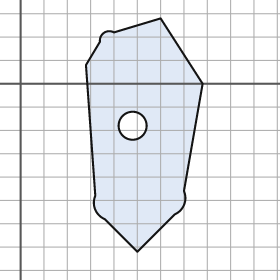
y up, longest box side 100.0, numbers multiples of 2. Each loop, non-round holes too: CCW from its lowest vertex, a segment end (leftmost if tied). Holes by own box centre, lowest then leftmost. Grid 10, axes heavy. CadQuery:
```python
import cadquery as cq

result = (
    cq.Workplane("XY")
    .moveTo(50.0, -72.0)
    .lineTo(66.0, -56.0)
    .threePointArc((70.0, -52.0), (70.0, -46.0))
    .lineTo(78.0, 0.0)
    .lineTo(60.0, 28.0)
    .lineTo(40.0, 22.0)
    .threePointArc((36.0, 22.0), (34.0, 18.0))
    .lineTo(28.0, 8.0)
    .lineTo(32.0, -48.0)
    .threePointArc((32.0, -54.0), (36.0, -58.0))
    .close()
    .moveTo(48.0, -18.0)
    .circle(6.0)
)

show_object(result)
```